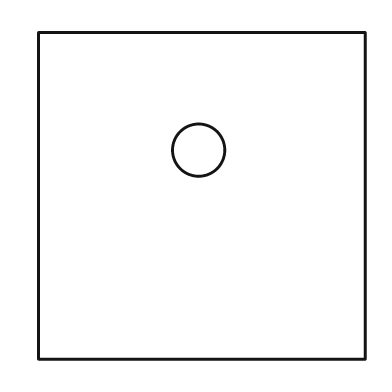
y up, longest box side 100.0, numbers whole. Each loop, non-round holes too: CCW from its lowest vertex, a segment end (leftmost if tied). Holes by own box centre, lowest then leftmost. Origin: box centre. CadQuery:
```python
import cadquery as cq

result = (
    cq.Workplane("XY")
    .moveTo(-50.0, -50.0)
    .lineTo(50.0, -50.0)
    .lineTo(50.0, 50.0)
    .lineTo(-50.0, 50.0)
    .close()
    .moveTo(-1.0, 14.0)
    .circle(8.0)
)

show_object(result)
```